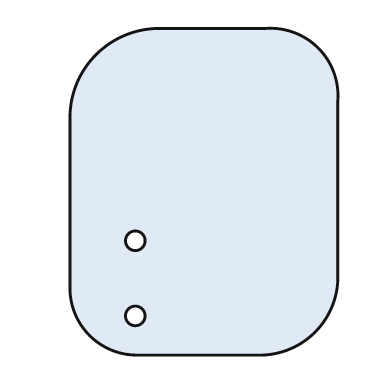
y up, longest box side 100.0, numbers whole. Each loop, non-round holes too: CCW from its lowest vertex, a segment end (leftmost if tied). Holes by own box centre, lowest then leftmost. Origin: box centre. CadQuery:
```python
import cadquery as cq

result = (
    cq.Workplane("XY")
    .moveTo(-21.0, -50.0)
    .lineTo(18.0, -50.0)
    .threePointArc((34.0, -43.0), (41.0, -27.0))
    .lineTo(41.0, 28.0)
    .threePointArc((35.0, 44.0), (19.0, 50.0))
    .lineTo(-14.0, 50.0)
    .threePointArc((-33.0, 42.0), (-41.0, 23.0))
    .lineTo(-41.0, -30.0)
    .threePointArc((-35.0, -44.0), (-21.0, -50.0))
    .close()
    .moveTo(-21.0, -38.0)
    .circle(3.0)
    .moveTo(-21.0, -15.0)
    .circle(3.0)
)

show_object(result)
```